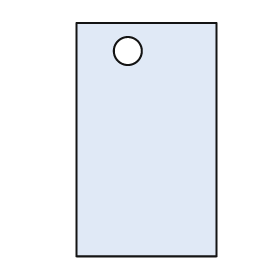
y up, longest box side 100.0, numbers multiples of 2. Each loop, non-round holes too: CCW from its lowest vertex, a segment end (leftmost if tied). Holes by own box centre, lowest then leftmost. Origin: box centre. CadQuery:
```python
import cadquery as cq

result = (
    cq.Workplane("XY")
    .moveTo(-30.0, -50.0)
    .lineTo(30.0, -50.0)
    .lineTo(30.0, 50.0)
    .lineTo(-30.0, 50.0)
    .close()
    .moveTo(-8.0, 38.0)
    .circle(6.0)
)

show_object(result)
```